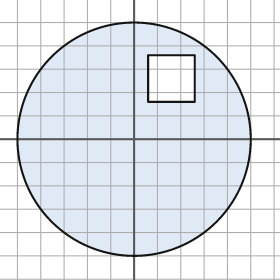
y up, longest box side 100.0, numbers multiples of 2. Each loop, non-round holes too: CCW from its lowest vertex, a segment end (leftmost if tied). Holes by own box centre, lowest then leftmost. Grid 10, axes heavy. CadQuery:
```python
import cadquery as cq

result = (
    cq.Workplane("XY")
    .moveTo(0.0, 0.0)
    .circle(50.0)
    .moveTo(6.0, 16.0)
    .lineTo(26.0, 16.0)
    .lineTo(26.0, 36.0)
    .lineTo(6.0, 36.0)
    .close()
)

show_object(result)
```